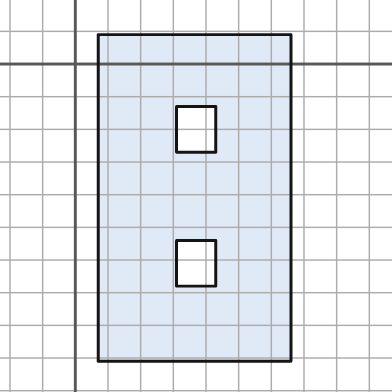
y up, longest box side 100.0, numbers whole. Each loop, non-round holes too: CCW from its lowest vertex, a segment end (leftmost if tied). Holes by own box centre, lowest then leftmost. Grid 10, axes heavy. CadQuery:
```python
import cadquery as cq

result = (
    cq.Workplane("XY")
    .moveTo(7.0, -91.0)
    .lineTo(66.0, -91.0)
    .lineTo(66.0, 9.0)
    .lineTo(7.0, 9.0)
    .close()
    .moveTo(31.0, -68.0)
    .lineTo(43.0, -68.0)
    .lineTo(43.0, -54.0)
    .lineTo(31.0, -54.0)
    .close()
    .moveTo(31.0, -27.0)
    .lineTo(43.0, -27.0)
    .lineTo(43.0, -13.0)
    .lineTo(31.0, -13.0)
    .close()
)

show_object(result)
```